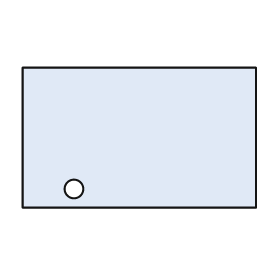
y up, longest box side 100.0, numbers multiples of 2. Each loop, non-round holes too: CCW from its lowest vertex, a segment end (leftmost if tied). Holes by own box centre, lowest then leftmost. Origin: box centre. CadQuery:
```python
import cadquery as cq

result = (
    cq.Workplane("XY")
    .moveTo(-50.0, -30.0)
    .lineTo(50.0, -30.0)
    .lineTo(50.0, 30.0)
    .lineTo(-50.0, 30.0)
    .close()
    .moveTo(-28.0, -22.0)
    .circle(4.0)
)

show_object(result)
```